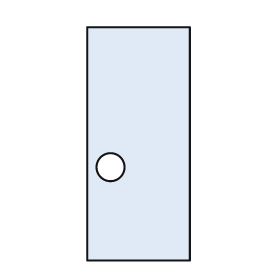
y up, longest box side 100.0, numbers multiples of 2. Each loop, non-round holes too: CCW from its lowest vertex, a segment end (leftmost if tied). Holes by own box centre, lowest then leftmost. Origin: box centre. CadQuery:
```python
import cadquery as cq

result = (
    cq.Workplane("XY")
    .moveTo(-22.0, -50.0)
    .lineTo(22.0, -50.0)
    .lineTo(22.0, 50.0)
    .lineTo(-22.0, 50.0)
    .close()
    .moveTo(-12.0, -10.0)
    .circle(6.0)
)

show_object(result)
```